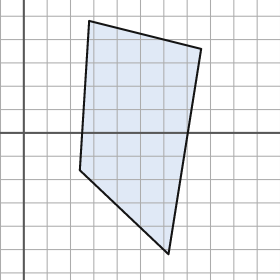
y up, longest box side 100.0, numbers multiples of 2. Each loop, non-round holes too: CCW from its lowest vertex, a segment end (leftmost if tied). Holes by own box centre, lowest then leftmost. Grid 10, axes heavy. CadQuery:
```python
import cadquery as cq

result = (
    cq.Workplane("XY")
    .moveTo(62.0, -52.0)
    .lineTo(76.0, 36.0)
    .lineTo(28.0, 48.0)
    .lineTo(24.0, -16.0)
    .close()
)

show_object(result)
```